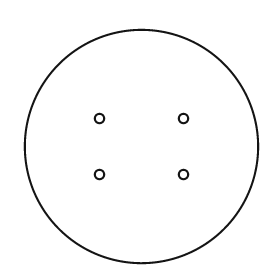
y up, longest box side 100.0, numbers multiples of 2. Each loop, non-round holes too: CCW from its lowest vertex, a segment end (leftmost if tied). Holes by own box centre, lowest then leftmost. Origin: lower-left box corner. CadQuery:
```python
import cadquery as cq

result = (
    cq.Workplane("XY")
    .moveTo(50.0, 50.0)
    .circle(50.0)
    .moveTo(32.0, 38.0)
    .circle(2.0)
    .moveTo(68.0, 38.0)
    .circle(2.0)
    .moveTo(32.0, 62.0)
    .circle(2.0)
    .moveTo(68.0, 62.0)
    .circle(2.0)
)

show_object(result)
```